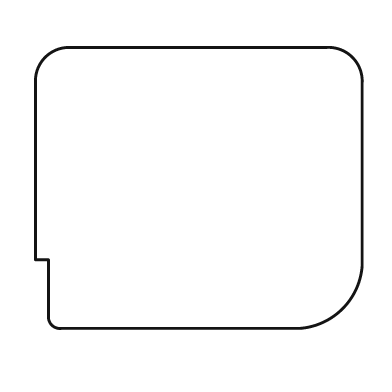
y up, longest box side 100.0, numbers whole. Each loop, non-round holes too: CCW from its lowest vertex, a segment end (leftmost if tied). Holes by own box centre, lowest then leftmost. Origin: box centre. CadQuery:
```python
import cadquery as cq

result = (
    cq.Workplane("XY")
    .moveTo(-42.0, -43.0)
    .lineTo(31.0, -43.0)
    .threePointArc((44.0, -37.0), (50.0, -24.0))
    .lineTo(50.0, 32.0)
    .threePointArc((47.0, 40.0), (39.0, 43.0))
    .lineTo(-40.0, 43.0)
    .threePointArc((-47.0, 40.0), (-50.0, 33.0))
    .lineTo(-50.0, -22.0)
    .lineTo(-46.0, -22.0)
    .lineTo(-46.0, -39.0)
    .threePointArc((-45.0, -42.0), (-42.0, -43.0))
    .close()
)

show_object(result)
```